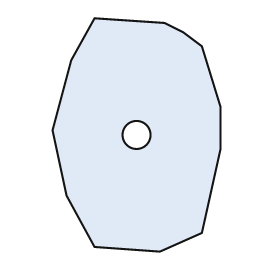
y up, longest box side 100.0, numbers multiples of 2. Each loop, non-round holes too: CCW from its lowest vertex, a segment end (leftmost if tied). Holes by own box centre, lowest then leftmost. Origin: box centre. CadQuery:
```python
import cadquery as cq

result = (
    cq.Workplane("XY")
    .moveTo(10.0, -50.0)
    .lineTo(28.0, -42.0)
    .lineTo(36.0, -6.0)
    .lineTo(36.0, 12.0)
    .lineTo(28.0, 38.0)
    .lineTo(20.0, 44.0)
    .lineTo(12.0, 48.0)
    .lineTo(-18.0, 50.0)
    .lineTo(-28.0, 32.0)
    .lineTo(-36.0, 2.0)
    .lineTo(-30.0, -26.0)
    .lineTo(-18.0, -48.0)
    .close()
    .moveTo(0.0, 0.0)
    .circle(6.0)
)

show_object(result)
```